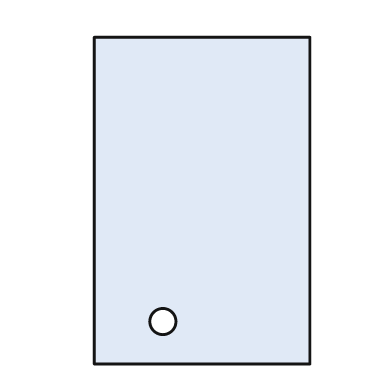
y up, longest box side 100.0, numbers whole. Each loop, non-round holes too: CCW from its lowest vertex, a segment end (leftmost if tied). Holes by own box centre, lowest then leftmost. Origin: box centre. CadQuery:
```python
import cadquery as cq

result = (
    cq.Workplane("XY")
    .moveTo(-33.0, -50.0)
    .lineTo(33.0, -50.0)
    .lineTo(33.0, 50.0)
    .lineTo(-33.0, 50.0)
    .close()
    .moveTo(-12.0, -37.0)
    .circle(4.0)
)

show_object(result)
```